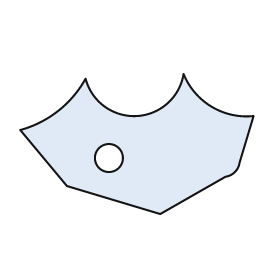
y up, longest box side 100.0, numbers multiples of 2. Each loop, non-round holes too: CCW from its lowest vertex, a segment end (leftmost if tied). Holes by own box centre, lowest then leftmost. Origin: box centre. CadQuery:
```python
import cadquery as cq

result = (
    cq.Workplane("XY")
    .moveTo(10.0, -30.0)
    .lineTo(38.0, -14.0)
    .threePointArc((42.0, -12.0), (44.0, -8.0))
    .lineTo(50.0, 12.0)
    .threePointArc((32.0, 16.0), (20.0, 30.0))
    .threePointArc((0.0, 12.0), (-22.0, 28.0))
    .threePointArc((-34.0, 14.0), (-50.0, 6.0))
    .lineTo(-30.0, -18.0)
    .close()
    .moveTo(-12.0, -6.0)
    .circle(6.0)
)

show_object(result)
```